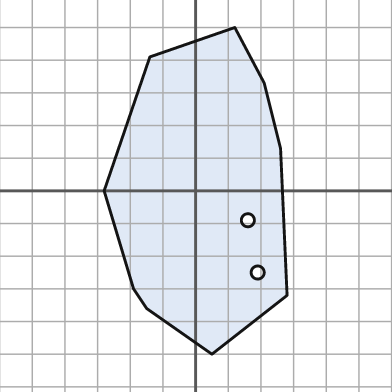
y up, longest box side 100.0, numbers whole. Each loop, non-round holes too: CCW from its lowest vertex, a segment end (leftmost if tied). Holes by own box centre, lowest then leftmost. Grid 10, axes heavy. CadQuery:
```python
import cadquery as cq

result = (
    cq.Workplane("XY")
    .moveTo(5.0, -50.0)
    .lineTo(28.0, -32.0)
    .lineTo(26.0, 13.0)
    .lineTo(21.0, 33.0)
    .lineTo(12.0, 50.0)
    .lineTo(-14.0, 41.0)
    .lineTo(-28.0, 0.0)
    .lineTo(-19.0, -30.0)
    .lineTo(-15.0, -36.0)
    .close()
    .moveTo(19.0, -25.0)
    .circle(2.0)
    .moveTo(16.0, -9.0)
    .circle(2.0)
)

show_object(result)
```